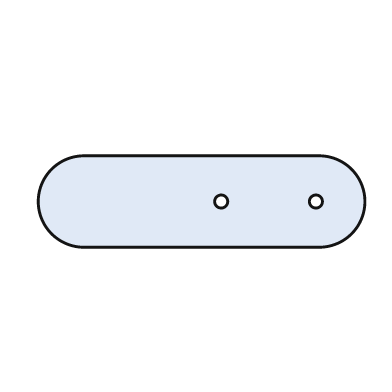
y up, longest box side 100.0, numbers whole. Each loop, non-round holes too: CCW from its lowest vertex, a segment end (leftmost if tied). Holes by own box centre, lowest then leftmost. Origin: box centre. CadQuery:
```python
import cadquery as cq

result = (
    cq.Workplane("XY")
    .moveTo(-36.0, -14.0)
    .lineTo(36.0, -14.0)
    .threePointArc((50.0, 0.0), (36.0, 14.0))
    .lineTo(-36.0, 14.0)
    .threePointArc((-50.0, 0.0), (-36.0, -14.0))
    .close()
    .moveTo(6.0, 0.0)
    .circle(2.0)
    .moveTo(35.0, 0.0)
    .circle(2.0)
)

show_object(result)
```